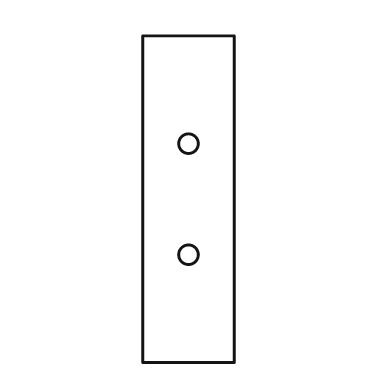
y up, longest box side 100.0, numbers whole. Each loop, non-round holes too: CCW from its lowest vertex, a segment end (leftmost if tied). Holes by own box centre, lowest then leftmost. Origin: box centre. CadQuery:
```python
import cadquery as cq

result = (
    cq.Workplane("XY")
    .moveTo(-14.0, -50.0)
    .lineTo(14.0, -50.0)
    .lineTo(14.0, 50.0)
    .lineTo(-14.0, 50.0)
    .close()
    .moveTo(0.0, -17.0)
    .circle(3.0)
    .moveTo(0.0, 17.0)
    .circle(3.0)
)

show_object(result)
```